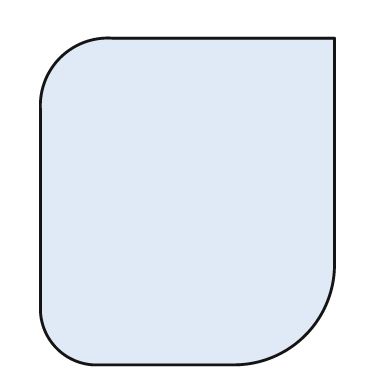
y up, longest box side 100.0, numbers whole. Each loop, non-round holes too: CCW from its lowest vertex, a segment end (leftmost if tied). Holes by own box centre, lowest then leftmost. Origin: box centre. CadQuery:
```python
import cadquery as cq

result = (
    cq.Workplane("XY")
    .moveTo(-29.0, -50.0)
    .lineTo(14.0, -50.0)
    .threePointArc((36.0, -41.0), (45.0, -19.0))
    .lineTo(45.0, 50.0)
    .lineTo(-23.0, 50.0)
    .threePointArc((-39.0, 44.0), (-45.0, 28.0))
    .lineTo(-45.0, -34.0)
    .threePointArc((-40.0, -45.0), (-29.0, -50.0))
    .close()
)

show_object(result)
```